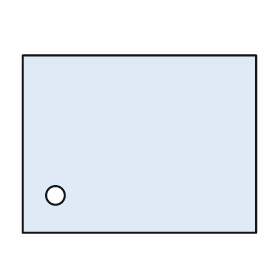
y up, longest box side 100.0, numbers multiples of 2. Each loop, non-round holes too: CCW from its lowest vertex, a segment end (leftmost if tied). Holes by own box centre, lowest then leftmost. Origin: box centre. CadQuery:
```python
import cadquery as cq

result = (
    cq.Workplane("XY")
    .moveTo(-50.0, -38.0)
    .lineTo(50.0, -38.0)
    .lineTo(50.0, 38.0)
    .lineTo(-50.0, 38.0)
    .close()
    .moveTo(-36.0, -22.0)
    .circle(4.0)
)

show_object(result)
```